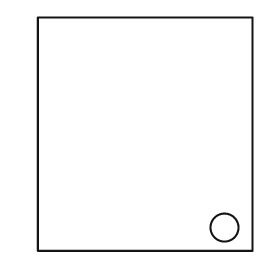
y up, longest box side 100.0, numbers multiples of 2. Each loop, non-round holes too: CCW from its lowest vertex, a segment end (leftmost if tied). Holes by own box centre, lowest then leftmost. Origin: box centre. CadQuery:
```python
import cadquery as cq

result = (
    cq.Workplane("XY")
    .moveTo(-46.0, -50.0)
    .lineTo(46.0, -50.0)
    .lineTo(46.0, 50.0)
    .lineTo(-46.0, 50.0)
    .close()
    .moveTo(34.0, -40.0)
    .circle(6.0)
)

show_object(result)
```